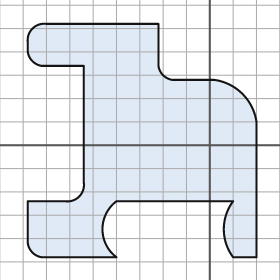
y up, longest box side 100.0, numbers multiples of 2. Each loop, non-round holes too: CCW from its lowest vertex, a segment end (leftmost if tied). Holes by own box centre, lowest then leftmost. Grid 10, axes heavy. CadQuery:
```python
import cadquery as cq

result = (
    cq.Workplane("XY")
    .moveTo(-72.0, -48.0)
    .lineTo(-40.0, -48.0)
    .threePointArc((-46.0, -36.0), (-40.0, -24.0))
    .lineTo(10.0, -24.0)
    .threePointArc((6.0, -36.0), (10.0, -48.0))
    .lineTo(20.0, -48.0)
    .lineTo(20.0, 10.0)
    .threePointArc((14.0, 22.0), (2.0, 28.0))
    .lineTo(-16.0, 28.0)
    .threePointArc((-20.0, 30.0), (-22.0, 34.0))
    .lineTo(-22.0, 52.0)
    .lineTo(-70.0, 52.0)
    .threePointArc((-76.0, 50.0), (-78.0, 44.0))
    .lineTo(-78.0, 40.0)
    .threePointArc((-76.0, 36.0), (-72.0, 34.0))
    .lineTo(-54.0, 34.0)
    .lineTo(-54.0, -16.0)
    .threePointArc((-56.0, -22.0), (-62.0, -24.0))
    .lineTo(-78.0, -24.0)
    .lineTo(-78.0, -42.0)
    .threePointArc((-76.0, -46.0), (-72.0, -48.0))
    .close()
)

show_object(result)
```